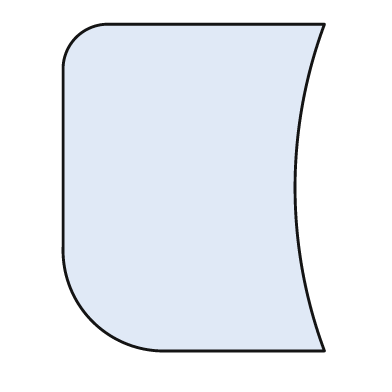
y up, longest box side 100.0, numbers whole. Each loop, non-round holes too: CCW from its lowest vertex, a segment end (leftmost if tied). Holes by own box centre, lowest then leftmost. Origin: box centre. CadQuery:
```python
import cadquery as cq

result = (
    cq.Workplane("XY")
    .moveTo(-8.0, -50.0)
    .lineTo(40.0, -50.0)
    .threePointArc((31.0, 0.0), (40.0, 50.0))
    .lineTo(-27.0, 50.0)
    .threePointArc((-36.0, 46.0), (-40.0, 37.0))
    .lineTo(-40.0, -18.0)
    .threePointArc((-31.0, -41.0), (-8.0, -50.0))
    .close()
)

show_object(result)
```